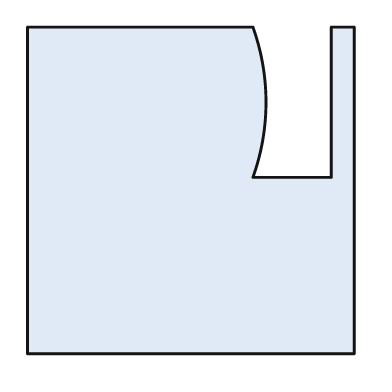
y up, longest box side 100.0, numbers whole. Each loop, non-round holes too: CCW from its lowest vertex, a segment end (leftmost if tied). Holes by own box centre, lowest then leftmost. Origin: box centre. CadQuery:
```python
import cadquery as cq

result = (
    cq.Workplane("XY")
    .moveTo(-50.0, -50.0)
    .lineTo(50.0, -50.0)
    .lineTo(50.0, 50.0)
    .lineTo(43.0, 50.0)
    .lineTo(43.0, 4.0)
    .lineTo(19.0, 4.0)
    .threePointArc((23.0, 27.0), (19.0, 50.0))
    .lineTo(-50.0, 50.0)
    .close()
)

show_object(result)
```